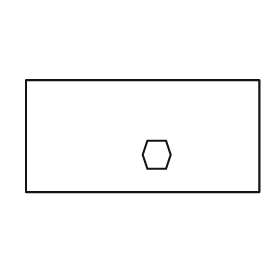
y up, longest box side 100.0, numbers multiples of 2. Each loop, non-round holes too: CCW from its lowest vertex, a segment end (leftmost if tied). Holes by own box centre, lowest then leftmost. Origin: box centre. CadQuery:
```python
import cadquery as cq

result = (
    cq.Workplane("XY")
    .moveTo(-50.0, -24.0)
    .lineTo(50.0, -24.0)
    .lineTo(50.0, 24.0)
    .lineTo(-50.0, 24.0)
    .close()
    .moveTo(2.0, -14.0)
    .lineTo(10.0, -14.0)
    .lineTo(12.0, -8.0)
    .lineTo(10.0, -2.0)
    .lineTo(2.0, -2.0)
    .lineTo(0.0, -8.0)
    .close()
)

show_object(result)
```